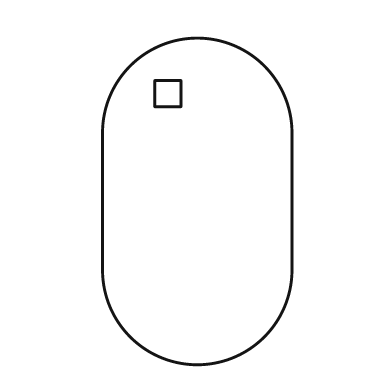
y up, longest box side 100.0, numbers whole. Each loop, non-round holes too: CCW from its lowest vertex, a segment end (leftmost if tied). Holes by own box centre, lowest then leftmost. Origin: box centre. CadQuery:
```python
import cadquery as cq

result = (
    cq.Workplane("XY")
    .moveTo(-29.0, -21.0)
    .threePointArc((0.0, -50.0), (29.0, -21.0))
    .lineTo(29.0, 21.0)
    .threePointArc((0.0, 50.0), (-29.0, 21.0))
    .close()
    .moveTo(-13.0, 29.0)
    .lineTo(-5.0, 29.0)
    .lineTo(-5.0, 37.0)
    .lineTo(-13.0, 37.0)
    .close()
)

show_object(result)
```